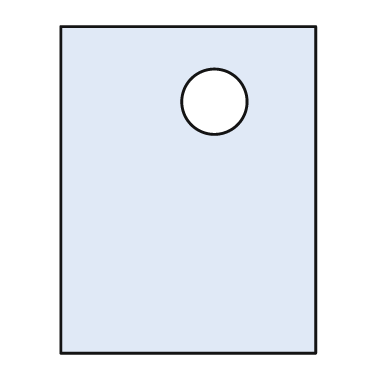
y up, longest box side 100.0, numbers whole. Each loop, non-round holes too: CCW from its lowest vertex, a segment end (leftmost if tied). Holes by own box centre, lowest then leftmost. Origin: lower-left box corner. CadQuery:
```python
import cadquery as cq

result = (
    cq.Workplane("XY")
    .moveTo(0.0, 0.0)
    .lineTo(78.0, 0.0)
    .lineTo(78.0, 100.0)
    .lineTo(0.0, 100.0)
    .close()
    .moveTo(47.0, 77.0)
    .circle(10.0)
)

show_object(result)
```